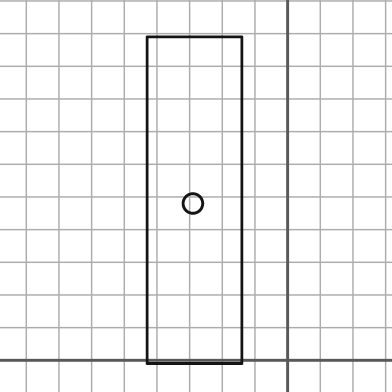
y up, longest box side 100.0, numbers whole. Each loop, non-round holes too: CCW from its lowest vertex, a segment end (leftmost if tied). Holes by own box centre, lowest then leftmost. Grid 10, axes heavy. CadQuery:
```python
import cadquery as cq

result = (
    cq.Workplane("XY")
    .moveTo(-43.0, -1.0)
    .lineTo(-14.0, -1.0)
    .lineTo(-14.0, 99.0)
    .lineTo(-43.0, 99.0)
    .close()
    .moveTo(-29.0, 48.0)
    .circle(3.0)
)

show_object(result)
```